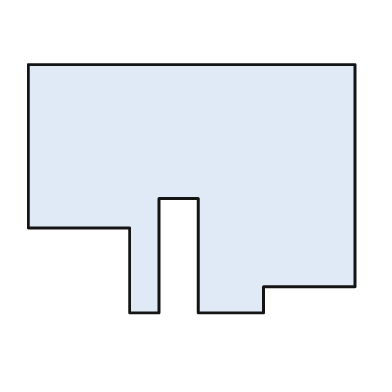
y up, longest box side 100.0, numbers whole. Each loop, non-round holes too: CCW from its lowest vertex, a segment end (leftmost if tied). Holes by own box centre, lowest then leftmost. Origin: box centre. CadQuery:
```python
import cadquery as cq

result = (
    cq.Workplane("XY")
    .moveTo(-19.0, -38.0)
    .lineTo(-10.0, -38.0)
    .lineTo(-10.0, -3.0)
    .lineTo(2.0, -3.0)
    .lineTo(2.0, -38.0)
    .lineTo(22.0, -38.0)
    .lineTo(22.0, -30.0)
    .lineTo(50.0, -30.0)
    .lineTo(50.0, 38.0)
    .lineTo(-50.0, 38.0)
    .lineTo(-50.0, -12.0)
    .lineTo(-19.0, -12.0)
    .close()
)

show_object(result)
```